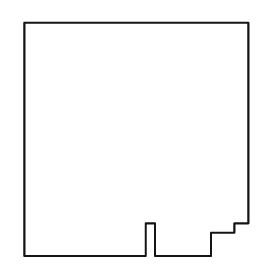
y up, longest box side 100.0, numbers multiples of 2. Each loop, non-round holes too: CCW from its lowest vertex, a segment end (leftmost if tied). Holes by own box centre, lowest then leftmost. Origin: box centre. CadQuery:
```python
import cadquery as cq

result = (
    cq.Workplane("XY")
    .moveTo(-48.0, -50.0)
    .lineTo(4.0, -50.0)
    .lineTo(4.0, -36.0)
    .lineTo(8.0, -36.0)
    .lineTo(8.0, -50.0)
    .lineTo(32.0, -50.0)
    .lineTo(32.0, -40.0)
    .lineTo(42.0, -40.0)
    .lineTo(42.0, -36.0)
    .lineTo(48.0, -36.0)
    .lineTo(48.0, 50.0)
    .lineTo(-48.0, 50.0)
    .close()
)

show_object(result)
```